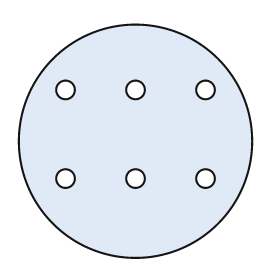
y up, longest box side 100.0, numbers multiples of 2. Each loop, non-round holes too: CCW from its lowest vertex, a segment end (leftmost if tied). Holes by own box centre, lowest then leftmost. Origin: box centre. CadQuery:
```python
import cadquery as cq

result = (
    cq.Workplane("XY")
    .moveTo(0.0, 0.0)
    .circle(50.0)
    .moveTo(-30.0, -16.0)
    .circle(4.0)
    .moveTo(0.0, -16.0)
    .circle(4.0)
    .moveTo(30.0, -16.0)
    .circle(4.0)
    .moveTo(-30.0, 22.0)
    .circle(4.0)
    .moveTo(0.0, 22.0)
    .circle(4.0)
    .moveTo(30.0, 22.0)
    .circle(4.0)
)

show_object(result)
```